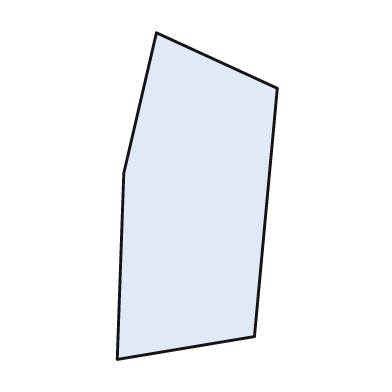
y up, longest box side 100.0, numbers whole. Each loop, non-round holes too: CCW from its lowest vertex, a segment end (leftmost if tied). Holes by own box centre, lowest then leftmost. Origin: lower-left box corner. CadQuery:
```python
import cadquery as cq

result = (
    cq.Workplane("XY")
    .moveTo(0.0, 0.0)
    .lineTo(42.0, 7.0)
    .lineTo(49.0, 83.0)
    .lineTo(12.0, 100.0)
    .lineTo(2.0, 57.0)
    .close()
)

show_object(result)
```